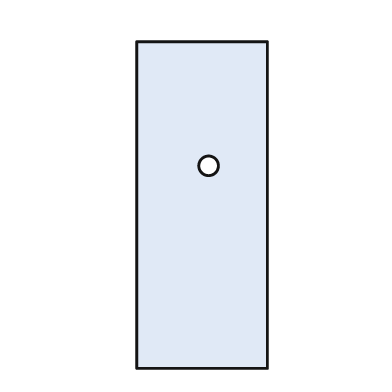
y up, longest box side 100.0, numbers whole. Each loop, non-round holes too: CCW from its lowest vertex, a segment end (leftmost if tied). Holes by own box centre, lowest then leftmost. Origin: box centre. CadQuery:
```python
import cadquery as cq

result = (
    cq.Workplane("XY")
    .moveTo(-20.0, -50.0)
    .lineTo(20.0, -50.0)
    .lineTo(20.0, 50.0)
    .lineTo(-20.0, 50.0)
    .close()
    .moveTo(2.0, 12.0)
    .circle(3.0)
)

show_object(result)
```